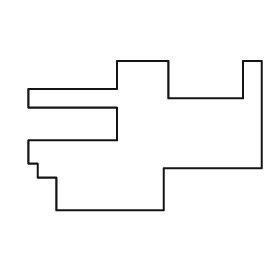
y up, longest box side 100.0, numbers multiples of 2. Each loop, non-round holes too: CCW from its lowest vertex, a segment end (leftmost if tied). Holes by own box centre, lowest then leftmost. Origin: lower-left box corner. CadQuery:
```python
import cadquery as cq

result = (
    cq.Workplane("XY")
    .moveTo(12.0, 0.0)
    .lineTo(58.0, 0.0)
    .lineTo(58.0, 18.0)
    .lineTo(100.0, 18.0)
    .lineTo(100.0, 64.0)
    .lineTo(92.0, 64.0)
    .lineTo(92.0, 48.0)
    .lineTo(60.0, 48.0)
    .lineTo(60.0, 64.0)
    .lineTo(38.0, 64.0)
    .lineTo(38.0, 52.0)
    .lineTo(0.0, 52.0)
    .lineTo(0.0, 44.0)
    .lineTo(38.0, 44.0)
    .lineTo(38.0, 30.0)
    .lineTo(0.0, 30.0)
    .lineTo(0.0, 20.0)
    .lineTo(4.0, 20.0)
    .lineTo(4.0, 14.0)
    .lineTo(12.0, 14.0)
    .close()
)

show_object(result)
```